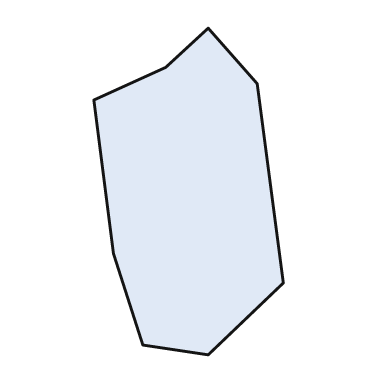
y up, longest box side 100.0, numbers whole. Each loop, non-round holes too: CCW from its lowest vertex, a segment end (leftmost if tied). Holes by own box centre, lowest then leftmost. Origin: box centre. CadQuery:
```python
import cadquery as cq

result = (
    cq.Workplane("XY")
    .moveTo(6.0, -50.0)
    .lineTo(29.0, -28.0)
    .lineTo(21.0, 33.0)
    .lineTo(6.0, 50.0)
    .lineTo(-7.0, 38.0)
    .lineTo(-29.0, 28.0)
    .lineTo(-23.0, -19.0)
    .lineTo(-14.0, -47.0)
    .close()
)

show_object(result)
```